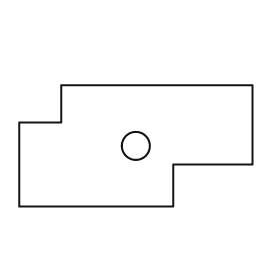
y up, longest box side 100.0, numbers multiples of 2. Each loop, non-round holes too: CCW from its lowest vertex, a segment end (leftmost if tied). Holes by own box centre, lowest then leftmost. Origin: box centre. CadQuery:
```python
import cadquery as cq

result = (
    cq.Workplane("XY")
    .moveTo(-50.0, -26.0)
    .lineTo(16.0, -26.0)
    .lineTo(16.0, -8.0)
    .lineTo(50.0, -8.0)
    .lineTo(50.0, 26.0)
    .lineTo(-32.0, 26.0)
    .lineTo(-32.0, 10.0)
    .lineTo(-50.0, 10.0)
    .close()
    .moveTo(0.0, 0.0)
    .circle(6.0)
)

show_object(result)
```